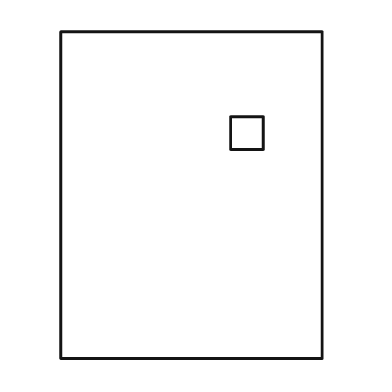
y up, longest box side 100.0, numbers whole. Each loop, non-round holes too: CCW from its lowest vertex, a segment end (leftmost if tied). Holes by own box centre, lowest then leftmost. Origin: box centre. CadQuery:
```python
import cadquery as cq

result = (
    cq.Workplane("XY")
    .moveTo(-40.0, -50.0)
    .lineTo(40.0, -50.0)
    .lineTo(40.0, 50.0)
    .lineTo(-40.0, 50.0)
    .close()
    .moveTo(12.0, 14.0)
    .lineTo(22.0, 14.0)
    .lineTo(22.0, 24.0)
    .lineTo(12.0, 24.0)
    .close()
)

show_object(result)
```